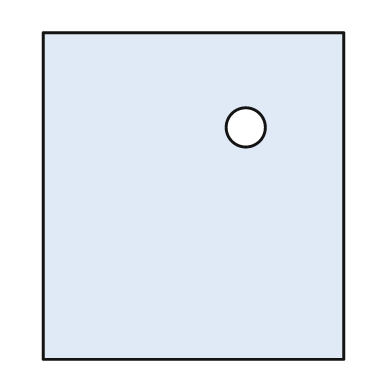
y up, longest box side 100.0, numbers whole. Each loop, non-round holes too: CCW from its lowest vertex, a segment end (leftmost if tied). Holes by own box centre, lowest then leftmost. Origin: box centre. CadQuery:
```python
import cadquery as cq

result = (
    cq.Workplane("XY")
    .moveTo(-46.0, -50.0)
    .lineTo(46.0, -50.0)
    .lineTo(46.0, 50.0)
    .lineTo(-46.0, 50.0)
    .close()
    .moveTo(16.0, 21.0)
    .circle(6.0)
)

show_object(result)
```